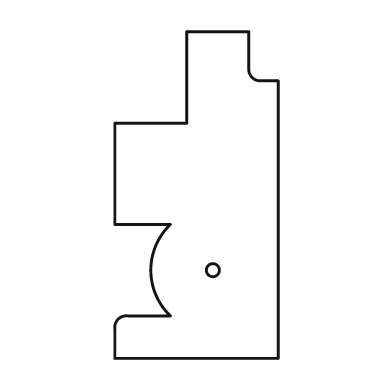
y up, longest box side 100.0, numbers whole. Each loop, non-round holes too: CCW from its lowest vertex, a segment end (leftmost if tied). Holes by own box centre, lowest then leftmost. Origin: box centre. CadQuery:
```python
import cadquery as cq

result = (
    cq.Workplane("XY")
    .moveTo(-25.0, -50.0)
    .lineTo(25.0, -50.0)
    .lineTo(25.0, 35.0)
    .lineTo(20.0, 35.0)
    .threePointArc((17.0, 36.0), (16.0, 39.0))
    .lineTo(16.0, 50.0)
    .lineTo(-3.0, 50.0)
    .lineTo(-3.0, 22.0)
    .lineTo(-25.0, 22.0)
    .lineTo(-25.0, -9.0)
    .lineTo(-8.0, -9.0)
    .threePointArc((-14.0, -23.0), (-8.0, -37.0))
    .lineTo(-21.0, -37.0)
    .threePointArc((-24.0, -38.0), (-25.0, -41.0))
    .close()
    .moveTo(5.0, -23.0)
    .circle(2.0)
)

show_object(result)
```